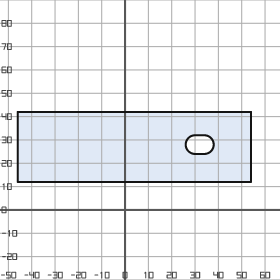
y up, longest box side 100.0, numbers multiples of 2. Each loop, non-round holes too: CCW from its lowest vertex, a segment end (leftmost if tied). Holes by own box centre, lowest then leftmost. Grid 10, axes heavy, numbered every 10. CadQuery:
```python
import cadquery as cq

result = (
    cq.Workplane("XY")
    .moveTo(-46.0, 12.0)
    .lineTo(54.0, 12.0)
    .lineTo(54.0, 42.0)
    .lineTo(-46.0, 42.0)
    .close()
    .moveTo(30.0, 24.0)
    .lineTo(34.0, 24.0)
    .threePointArc((38.0, 28.0), (34.0, 32.0))
    .lineTo(30.0, 32.0)
    .threePointArc((26.0, 28.0), (30.0, 24.0))
    .close()
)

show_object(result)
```